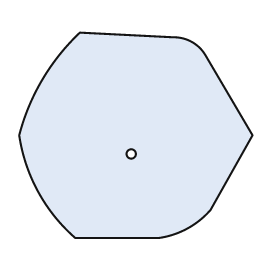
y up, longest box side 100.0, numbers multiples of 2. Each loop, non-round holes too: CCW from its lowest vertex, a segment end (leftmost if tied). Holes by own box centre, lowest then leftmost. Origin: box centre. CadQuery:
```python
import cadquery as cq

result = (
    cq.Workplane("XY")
    .moveTo(-26.0, -44.0)
    .lineTo(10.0, -44.0)
    .threePointArc((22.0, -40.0), (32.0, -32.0))
    .lineTo(50.0, 0.0)
    .lineTo(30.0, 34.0)
    .threePointArc((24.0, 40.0), (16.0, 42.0))
    .lineTo(-24.0, 44.0)
    .threePointArc((-40.0, 24.0), (-50.0, 0.0))
    .threePointArc((-42.0, -24.0), (-26.0, -44.0))
    .close()
    .moveTo(-2.0, -8.0)
    .circle(2.0)
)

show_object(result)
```